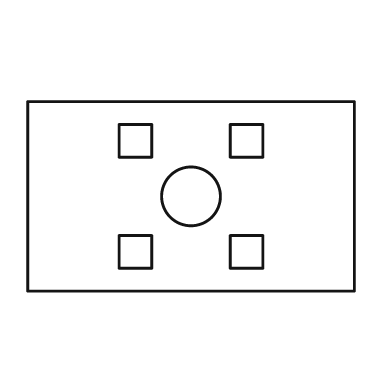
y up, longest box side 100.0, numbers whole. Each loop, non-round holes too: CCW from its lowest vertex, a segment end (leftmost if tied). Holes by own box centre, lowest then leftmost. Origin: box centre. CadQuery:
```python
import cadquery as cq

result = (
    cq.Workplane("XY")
    .moveTo(-50.0, -29.0)
    .lineTo(50.0, -29.0)
    .lineTo(50.0, 29.0)
    .lineTo(-50.0, 29.0)
    .close()
    .moveTo(-22.0, -22.0)
    .lineTo(-12.0, -22.0)
    .lineTo(-12.0, -12.0)
    .lineTo(-22.0, -12.0)
    .close()
    .moveTo(12.0, -22.0)
    .lineTo(22.0, -22.0)
    .lineTo(22.0, -12.0)
    .lineTo(12.0, -12.0)
    .close()
    .moveTo(0.0, 0.0)
    .circle(9.0)
    .moveTo(-22.0, 12.0)
    .lineTo(-12.0, 12.0)
    .lineTo(-12.0, 22.0)
    .lineTo(-22.0, 22.0)
    .close()
    .moveTo(12.0, 12.0)
    .lineTo(22.0, 12.0)
    .lineTo(22.0, 22.0)
    .lineTo(12.0, 22.0)
    .close()
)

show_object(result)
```